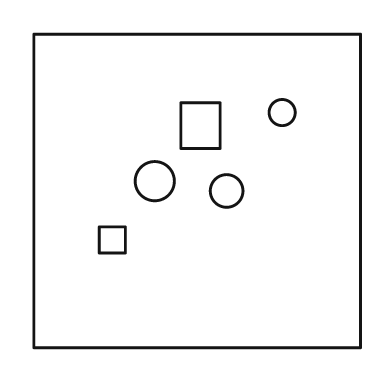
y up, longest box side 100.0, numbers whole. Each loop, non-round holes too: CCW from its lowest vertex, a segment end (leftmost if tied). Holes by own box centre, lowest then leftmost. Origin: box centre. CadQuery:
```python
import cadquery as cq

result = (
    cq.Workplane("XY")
    .moveTo(-50.0, -48.0)
    .lineTo(50.0, -48.0)
    .lineTo(50.0, 48.0)
    .lineTo(-50.0, 48.0)
    .close()
    .moveTo(-30.0, -19.0)
    .lineTo(-22.0, -19.0)
    .lineTo(-22.0, -11.0)
    .lineTo(-30.0, -11.0)
    .close()
    .moveTo(9.0, 0.0)
    .circle(5.0)
    .moveTo(-13.0, 3.0)
    .circle(6.0)
    .moveTo(-5.0, 13.0)
    .lineTo(7.0, 13.0)
    .lineTo(7.0, 27.0)
    .lineTo(-5.0, 27.0)
    .close()
    .moveTo(26.0, 24.0)
    .circle(4.0)
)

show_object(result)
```